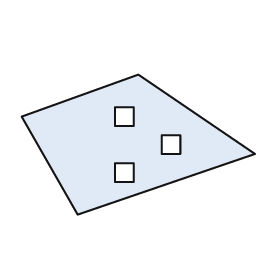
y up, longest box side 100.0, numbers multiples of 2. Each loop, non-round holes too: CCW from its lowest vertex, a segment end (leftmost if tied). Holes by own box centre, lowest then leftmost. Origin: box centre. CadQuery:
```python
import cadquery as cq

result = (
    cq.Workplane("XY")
    .moveTo(-26.0, -30.0)
    .lineTo(50.0, -4.0)
    .lineTo(0.0, 30.0)
    .lineTo(-50.0, 12.0)
    .close()
    .moveTo(-10.0, -16.0)
    .lineTo(-2.0, -16.0)
    .lineTo(-2.0, -8.0)
    .lineTo(-10.0, -8.0)
    .close()
    .moveTo(10.0, -4.0)
    .lineTo(18.0, -4.0)
    .lineTo(18.0, 4.0)
    .lineTo(10.0, 4.0)
    .close()
    .moveTo(-10.0, 8.0)
    .lineTo(-2.0, 8.0)
    .lineTo(-2.0, 16.0)
    .lineTo(-10.0, 16.0)
    .close()
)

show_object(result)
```